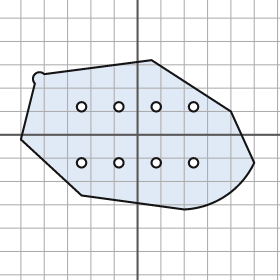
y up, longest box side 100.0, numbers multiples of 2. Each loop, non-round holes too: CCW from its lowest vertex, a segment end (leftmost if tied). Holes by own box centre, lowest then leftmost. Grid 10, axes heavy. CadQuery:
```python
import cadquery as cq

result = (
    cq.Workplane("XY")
    .moveTo(20.0, -32.0)
    .threePointArc((38.0, -26.0), (50.0, -12.0))
    .lineTo(40.0, 10.0)
    .lineTo(6.0, 32.0)
    .lineTo(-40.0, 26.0)
    .threePointArc((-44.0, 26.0), (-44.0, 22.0))
    .lineTo(-50.0, -2.0)
    .lineTo(-24.0, -26.0)
    .close()
    .moveTo(-24.0, -12.0)
    .circle(2.0)
    .moveTo(-8.0, -12.0)
    .circle(2.0)
    .moveTo(8.0, -12.0)
    .circle(2.0)
    .moveTo(24.0, -12.0)
    .circle(2.0)
    .moveTo(-24.0, 12.0)
    .circle(2.0)
    .moveTo(-8.0, 12.0)
    .circle(2.0)
    .moveTo(8.0, 12.0)
    .circle(2.0)
    .moveTo(24.0, 12.0)
    .circle(2.0)
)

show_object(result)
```